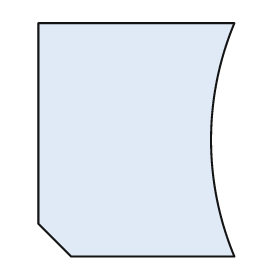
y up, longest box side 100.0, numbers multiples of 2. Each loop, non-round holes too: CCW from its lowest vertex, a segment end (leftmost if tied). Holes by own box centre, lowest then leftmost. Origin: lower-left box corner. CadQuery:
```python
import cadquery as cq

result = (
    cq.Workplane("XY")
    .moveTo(14.0, 0.0)
    .lineTo(84.0, 0.0)
    .threePointArc((74.0, 50.0), (84.0, 100.0))
    .lineTo(0.0, 100.0)
    .lineTo(0.0, 14.0)
    .close()
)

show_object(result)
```